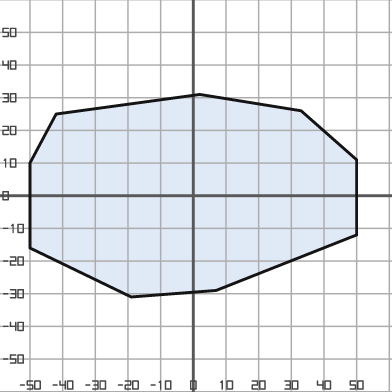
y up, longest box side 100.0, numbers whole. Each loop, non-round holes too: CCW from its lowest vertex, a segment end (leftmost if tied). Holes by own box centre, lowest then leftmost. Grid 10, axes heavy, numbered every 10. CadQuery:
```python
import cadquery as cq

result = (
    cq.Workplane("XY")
    .moveTo(-19.0, -31.0)
    .lineTo(7.0, -29.0)
    .lineTo(50.0, -12.0)
    .lineTo(50.0, 11.0)
    .lineTo(33.0, 26.0)
    .lineTo(2.0, 31.0)
    .lineTo(-42.0, 25.0)
    .lineTo(-50.0, 10.0)
    .lineTo(-50.0, -16.0)
    .close()
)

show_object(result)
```